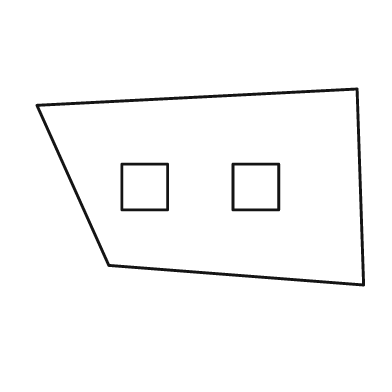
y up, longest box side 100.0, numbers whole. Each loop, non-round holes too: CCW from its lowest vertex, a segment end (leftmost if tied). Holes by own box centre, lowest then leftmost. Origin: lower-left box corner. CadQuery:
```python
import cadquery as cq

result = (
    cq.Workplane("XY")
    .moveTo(100.0, 0.0)
    .lineTo(98.0, 60.0)
    .lineTo(0.0, 55.0)
    .lineTo(22.0, 6.0)
    .close()
    .moveTo(26.0, 23.0)
    .lineTo(40.0, 23.0)
    .lineTo(40.0, 37.0)
    .lineTo(26.0, 37.0)
    .close()
    .moveTo(60.0, 23.0)
    .lineTo(74.0, 23.0)
    .lineTo(74.0, 37.0)
    .lineTo(60.0, 37.0)
    .close()
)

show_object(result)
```